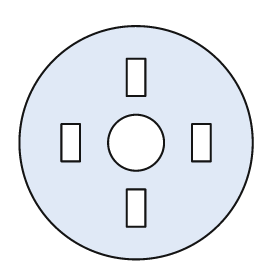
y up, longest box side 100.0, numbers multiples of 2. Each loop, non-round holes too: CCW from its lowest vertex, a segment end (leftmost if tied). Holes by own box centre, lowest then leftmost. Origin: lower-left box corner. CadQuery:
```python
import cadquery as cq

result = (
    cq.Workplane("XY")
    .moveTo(50.0, 50.0)
    .circle(50.0)
    .moveTo(46.0, 14.0)
    .lineTo(54.0, 14.0)
    .lineTo(54.0, 30.0)
    .lineTo(46.0, 30.0)
    .close()
    .moveTo(18.0, 42.0)
    .lineTo(26.0, 42.0)
    .lineTo(26.0, 58.0)
    .lineTo(18.0, 58.0)
    .close()
    .moveTo(50.0, 50.0)
    .circle(12.0)
    .moveTo(74.0, 42.0)
    .lineTo(82.0, 42.0)
    .lineTo(82.0, 58.0)
    .lineTo(74.0, 58.0)
    .close()
    .moveTo(46.0, 70.0)
    .lineTo(54.0, 70.0)
    .lineTo(54.0, 86.0)
    .lineTo(46.0, 86.0)
    .close()
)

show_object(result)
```